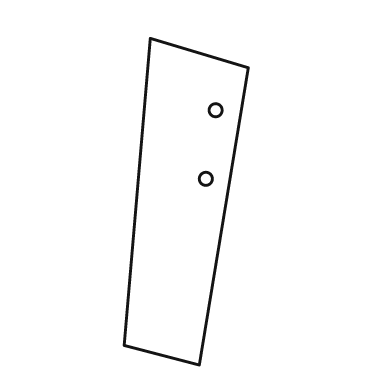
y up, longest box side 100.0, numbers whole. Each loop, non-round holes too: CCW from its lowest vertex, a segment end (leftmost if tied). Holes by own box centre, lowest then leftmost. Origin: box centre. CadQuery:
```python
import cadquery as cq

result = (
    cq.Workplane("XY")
    .moveTo(4.0, -50.0)
    .lineTo(19.0, 41.0)
    .lineTo(-11.0, 50.0)
    .lineTo(-19.0, -44.0)
    .close()
    .moveTo(6.0, 7.0)
    .circle(2.0)
    .moveTo(9.0, 28.0)
    .circle(2.0)
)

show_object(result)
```